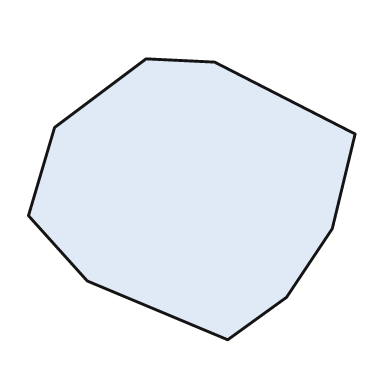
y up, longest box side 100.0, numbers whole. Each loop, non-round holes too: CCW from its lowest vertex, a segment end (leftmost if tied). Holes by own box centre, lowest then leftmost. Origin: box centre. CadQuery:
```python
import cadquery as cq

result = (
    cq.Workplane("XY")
    .moveTo(11.0, -43.0)
    .lineTo(29.0, -30.0)
    .lineTo(43.0, -9.0)
    .lineTo(50.0, 20.0)
    .lineTo(7.0, 42.0)
    .lineTo(-14.0, 43.0)
    .lineTo(-42.0, 22.0)
    .lineTo(-50.0, -5.0)
    .lineTo(-32.0, -25.0)
    .close()
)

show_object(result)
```